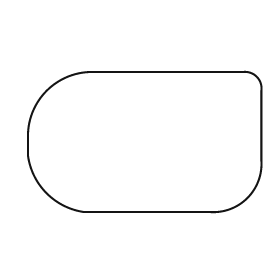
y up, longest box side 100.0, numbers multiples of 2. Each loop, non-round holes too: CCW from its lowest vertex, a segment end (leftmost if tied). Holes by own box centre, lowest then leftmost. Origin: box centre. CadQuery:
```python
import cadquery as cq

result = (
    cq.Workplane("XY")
    .moveTo(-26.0, -30.0)
    .lineTo(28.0, -30.0)
    .threePointArc((44.0, -24.0), (50.0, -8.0))
    .lineTo(50.0, 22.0)
    .threePointArc((48.0, 28.0), (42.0, 30.0))
    .lineTo(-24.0, 30.0)
    .threePointArc((-42.0, 22.0), (-50.0, 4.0))
    .lineTo(-50.0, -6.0)
    .threePointArc((-42.0, -22.0), (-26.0, -30.0))
    .close()
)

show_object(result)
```